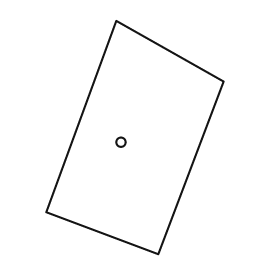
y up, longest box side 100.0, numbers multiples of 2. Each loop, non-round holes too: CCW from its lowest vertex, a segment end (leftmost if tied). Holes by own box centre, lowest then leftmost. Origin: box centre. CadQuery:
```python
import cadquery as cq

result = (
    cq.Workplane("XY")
    .moveTo(10.0, -50.0)
    .lineTo(38.0, 24.0)
    .lineTo(-8.0, 50.0)
    .lineTo(-38.0, -32.0)
    .close()
    .moveTo(-6.0, -2.0)
    .circle(2.0)
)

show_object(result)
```